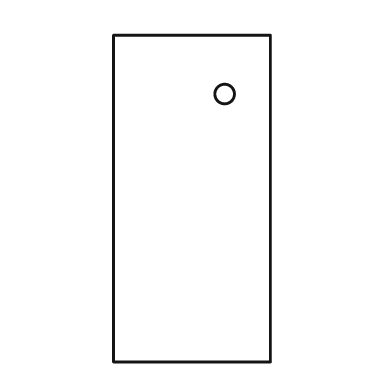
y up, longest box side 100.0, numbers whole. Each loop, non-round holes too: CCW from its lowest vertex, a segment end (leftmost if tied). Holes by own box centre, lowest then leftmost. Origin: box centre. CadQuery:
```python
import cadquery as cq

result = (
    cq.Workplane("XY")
    .moveTo(-24.0, -50.0)
    .lineTo(24.0, -50.0)
    .lineTo(24.0, 50.0)
    .lineTo(-24.0, 50.0)
    .close()
    .moveTo(10.0, 32.0)
    .circle(3.0)
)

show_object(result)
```